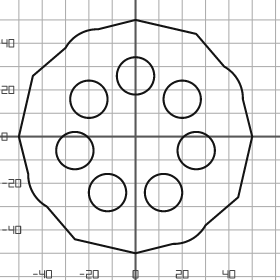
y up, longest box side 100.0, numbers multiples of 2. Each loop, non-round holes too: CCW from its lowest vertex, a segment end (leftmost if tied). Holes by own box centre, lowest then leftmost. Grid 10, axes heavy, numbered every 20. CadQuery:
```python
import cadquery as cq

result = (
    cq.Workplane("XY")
    .moveTo(0.0, -50.0)
    .lineTo(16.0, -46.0)
    .threePointArc((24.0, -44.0), (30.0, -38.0))
    .lineTo(44.0, -26.0)
    .lineTo(50.0, 0.0)
    .lineTo(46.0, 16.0)
    .threePointArc((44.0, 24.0), (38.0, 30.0))
    .lineTo(26.0, 44.0)
    .lineTo(0.0, 50.0)
    .lineTo(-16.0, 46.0)
    .threePointArc((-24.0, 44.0), (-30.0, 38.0))
    .lineTo(-44.0, 26.0)
    .lineTo(-50.0, 0.0)
    .lineTo(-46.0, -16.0)
    .threePointArc((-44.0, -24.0), (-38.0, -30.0))
    .lineTo(-26.0, -44.0)
    .close()
    .moveTo(-12.0, -24.0)
    .circle(8.0)
    .moveTo(12.0, -24.0)
    .circle(8.0)
    .moveTo(-26.0, -6.0)
    .circle(8.0)
    .moveTo(26.0, -6.0)
    .circle(8.0)
    .moveTo(-20.0, 16.0)
    .circle(8.0)
    .moveTo(20.0, 16.0)
    .circle(8.0)
    .moveTo(0.0, 26.0)
    .circle(8.0)
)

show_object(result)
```